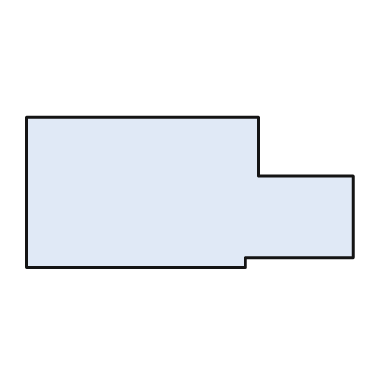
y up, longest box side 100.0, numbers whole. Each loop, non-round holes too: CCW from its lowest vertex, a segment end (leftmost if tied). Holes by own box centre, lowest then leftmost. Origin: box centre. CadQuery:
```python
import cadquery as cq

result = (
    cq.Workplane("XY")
    .moveTo(-50.0, -23.0)
    .lineTo(17.0, -23.0)
    .lineTo(17.0, -20.0)
    .lineTo(50.0, -20.0)
    .lineTo(50.0, 5.0)
    .lineTo(21.0, 5.0)
    .lineTo(21.0, 23.0)
    .lineTo(-50.0, 23.0)
    .close()
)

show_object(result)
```